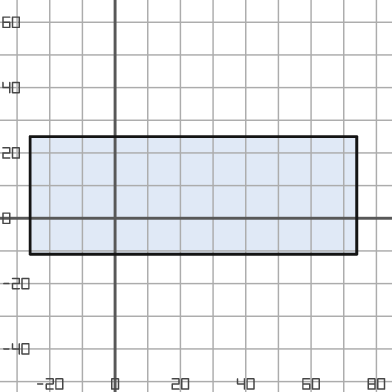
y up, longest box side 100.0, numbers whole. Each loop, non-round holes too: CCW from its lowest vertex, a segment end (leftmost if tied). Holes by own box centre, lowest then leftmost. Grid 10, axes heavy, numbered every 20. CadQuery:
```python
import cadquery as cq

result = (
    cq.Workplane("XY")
    .moveTo(-26.0, -11.0)
    .lineTo(74.0, -11.0)
    .lineTo(74.0, 25.0)
    .lineTo(-26.0, 25.0)
    .close()
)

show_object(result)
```